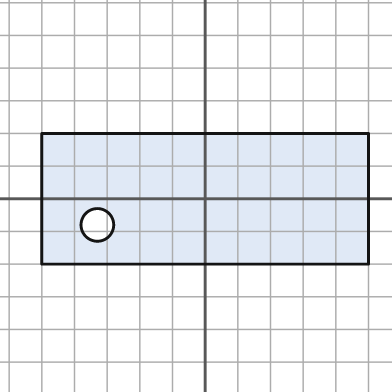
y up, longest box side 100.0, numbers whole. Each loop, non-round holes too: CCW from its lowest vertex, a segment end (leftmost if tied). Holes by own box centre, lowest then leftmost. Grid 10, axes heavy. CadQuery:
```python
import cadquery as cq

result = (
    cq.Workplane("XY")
    .moveTo(-50.0, -20.0)
    .lineTo(50.0, -20.0)
    .lineTo(50.0, 20.0)
    .lineTo(-50.0, 20.0)
    .close()
    .moveTo(-33.0, -8.0)
    .circle(5.0)
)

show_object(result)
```